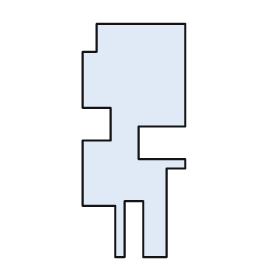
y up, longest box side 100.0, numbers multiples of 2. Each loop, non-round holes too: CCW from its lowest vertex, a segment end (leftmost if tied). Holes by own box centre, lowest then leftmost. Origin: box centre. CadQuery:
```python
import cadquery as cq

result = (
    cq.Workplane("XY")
    .moveTo(-8.0, -50.0)
    .lineTo(-4.0, -50.0)
    .lineTo(-4.0, -26.0)
    .lineTo(4.0, -26.0)
    .lineTo(4.0, -50.0)
    .lineTo(14.0, -50.0)
    .lineTo(14.0, -12.0)
    .lineTo(22.0, -12.0)
    .lineTo(22.0, -8.0)
    .lineTo(2.0, -8.0)
    .lineTo(2.0, 6.0)
    .lineTo(22.0, 6.0)
    .lineTo(22.0, 50.0)
    .lineTo(-16.0, 50.0)
    .lineTo(-16.0, 38.0)
    .lineTo(-22.0, 38.0)
    .lineTo(-22.0, 14.0)
    .lineTo(-10.0, 14.0)
    .lineTo(-10.0, 0.0)
    .lineTo(-22.0, 0.0)
    .lineTo(-22.0, -28.0)
    .lineTo(-8.0, -28.0)
    .close()
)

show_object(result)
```